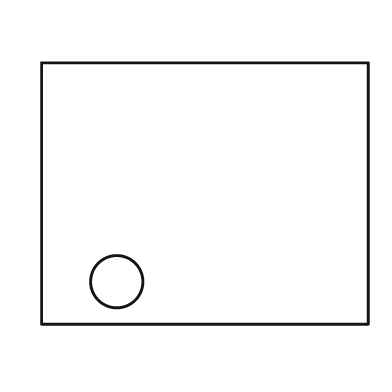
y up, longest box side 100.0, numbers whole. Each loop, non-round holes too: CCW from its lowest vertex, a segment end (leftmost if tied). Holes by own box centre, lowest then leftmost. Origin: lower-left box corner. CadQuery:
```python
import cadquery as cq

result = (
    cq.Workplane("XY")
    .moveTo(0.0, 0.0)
    .lineTo(100.0, 0.0)
    .lineTo(100.0, 80.0)
    .lineTo(0.0, 80.0)
    .close()
    .moveTo(23.0, 13.0)
    .circle(8.0)
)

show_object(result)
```